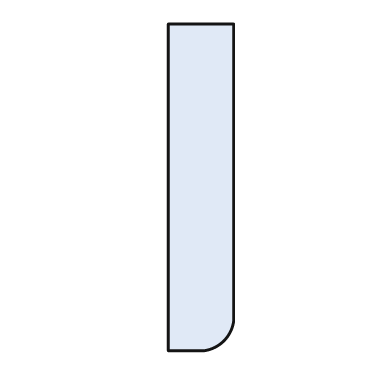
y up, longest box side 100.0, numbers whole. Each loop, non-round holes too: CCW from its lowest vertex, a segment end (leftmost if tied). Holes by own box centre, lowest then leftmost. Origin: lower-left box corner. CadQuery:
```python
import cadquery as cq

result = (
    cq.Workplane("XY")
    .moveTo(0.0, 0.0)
    .lineTo(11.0, 0.0)
    .threePointArc((17.0, 3.0), (20.0, 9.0))
    .lineTo(20.0, 100.0)
    .lineTo(0.0, 100.0)
    .close()
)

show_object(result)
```